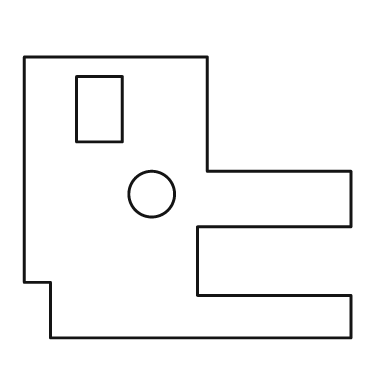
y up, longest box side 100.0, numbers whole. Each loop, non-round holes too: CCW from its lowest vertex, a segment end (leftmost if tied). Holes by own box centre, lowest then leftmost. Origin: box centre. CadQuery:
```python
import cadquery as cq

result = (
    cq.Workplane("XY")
    .moveTo(-42.0, -43.0)
    .lineTo(50.0, -43.0)
    .lineTo(50.0, -30.0)
    .lineTo(3.0, -30.0)
    .lineTo(3.0, -9.0)
    .lineTo(50.0, -9.0)
    .lineTo(50.0, 8.0)
    .lineTo(6.0, 8.0)
    .lineTo(6.0, 43.0)
    .lineTo(-50.0, 43.0)
    .lineTo(-50.0, -26.0)
    .lineTo(-42.0, -26.0)
    .close()
    .moveTo(-11.0, 1.0)
    .circle(7.0)
    .moveTo(-34.0, 17.0)
    .lineTo(-20.0, 17.0)
    .lineTo(-20.0, 37.0)
    .lineTo(-34.0, 37.0)
    .close()
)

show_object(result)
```